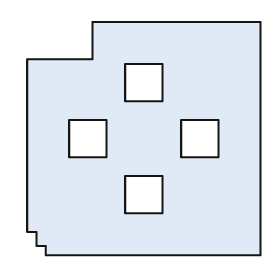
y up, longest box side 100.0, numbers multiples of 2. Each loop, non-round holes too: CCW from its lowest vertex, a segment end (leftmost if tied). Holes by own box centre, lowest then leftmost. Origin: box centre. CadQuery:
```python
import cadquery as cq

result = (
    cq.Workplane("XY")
    .moveTo(-42.0, -50.0)
    .lineTo(50.0, -50.0)
    .lineTo(50.0, 50.0)
    .lineTo(-22.0, 50.0)
    .lineTo(-22.0, 34.0)
    .lineTo(-50.0, 34.0)
    .lineTo(-50.0, -40.0)
    .lineTo(-46.0, -40.0)
    .lineTo(-46.0, -46.0)
    .lineTo(-42.0, -46.0)
    .close()
    .moveTo(-8.0, -32.0)
    .lineTo(8.0, -32.0)
    .lineTo(8.0, -16.0)
    .lineTo(-8.0, -16.0)
    .close()
    .moveTo(-32.0, -8.0)
    .lineTo(-16.0, -8.0)
    .lineTo(-16.0, 8.0)
    .lineTo(-32.0, 8.0)
    .close()
    .moveTo(16.0, -8.0)
    .lineTo(32.0, -8.0)
    .lineTo(32.0, 8.0)
    .lineTo(16.0, 8.0)
    .close()
    .moveTo(-8.0, 16.0)
    .lineTo(8.0, 16.0)
    .lineTo(8.0, 32.0)
    .lineTo(-8.0, 32.0)
    .close()
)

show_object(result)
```